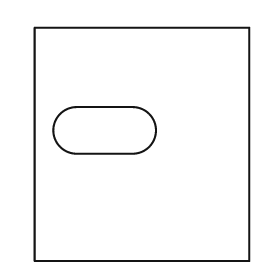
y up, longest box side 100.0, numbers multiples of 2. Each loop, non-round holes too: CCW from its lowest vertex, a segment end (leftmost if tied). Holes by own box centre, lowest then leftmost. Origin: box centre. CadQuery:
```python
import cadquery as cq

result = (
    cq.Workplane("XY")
    .moveTo(-46.0, -50.0)
    .lineTo(46.0, -50.0)
    .lineTo(46.0, 50.0)
    .lineTo(-46.0, 50.0)
    .close()
    .moveTo(-28.0, -4.0)
    .lineTo(-4.0, -4.0)
    .threePointArc((6.0, 6.0), (-4.0, 16.0))
    .lineTo(-28.0, 16.0)
    .threePointArc((-38.0, 6.0), (-28.0, -4.0))
    .close()
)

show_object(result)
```